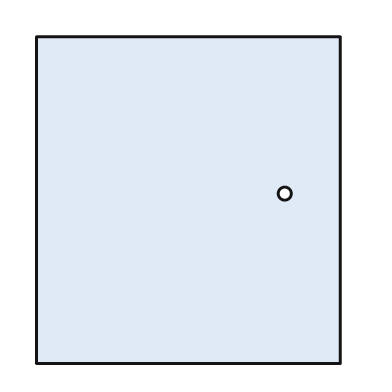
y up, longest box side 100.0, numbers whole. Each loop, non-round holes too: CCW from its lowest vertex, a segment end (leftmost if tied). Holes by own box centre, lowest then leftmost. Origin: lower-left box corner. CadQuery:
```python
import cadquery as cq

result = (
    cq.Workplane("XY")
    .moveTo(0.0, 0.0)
    .lineTo(93.0, 0.0)
    .lineTo(93.0, 100.0)
    .lineTo(0.0, 100.0)
    .close()
    .moveTo(76.0, 52.0)
    .circle(2.0)
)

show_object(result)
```